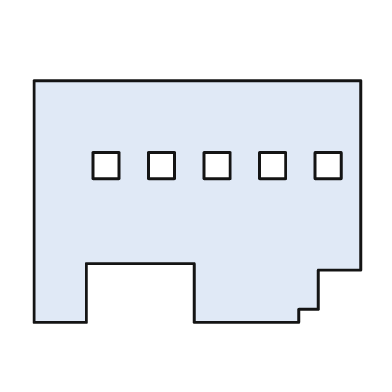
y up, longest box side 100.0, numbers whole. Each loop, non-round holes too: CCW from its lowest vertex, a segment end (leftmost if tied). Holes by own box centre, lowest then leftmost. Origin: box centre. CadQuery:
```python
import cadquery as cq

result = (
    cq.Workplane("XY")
    .moveTo(-50.0, -37.0)
    .lineTo(-34.0, -37.0)
    .lineTo(-34.0, -19.0)
    .lineTo(-1.0, -19.0)
    .lineTo(-1.0, -37.0)
    .lineTo(31.0, -37.0)
    .lineTo(31.0, -33.0)
    .lineTo(37.0, -33.0)
    .lineTo(37.0, -21.0)
    .lineTo(50.0, -21.0)
    .lineTo(50.0, 37.0)
    .lineTo(-50.0, 37.0)
    .close()
    .moveTo(-32.0, 7.0)
    .lineTo(-24.0, 7.0)
    .lineTo(-24.0, 15.0)
    .lineTo(-32.0, 15.0)
    .close()
    .moveTo(-15.0, 7.0)
    .lineTo(-7.0, 7.0)
    .lineTo(-7.0, 15.0)
    .lineTo(-15.0, 15.0)
    .close()
    .moveTo(2.0, 7.0)
    .lineTo(10.0, 7.0)
    .lineTo(10.0, 15.0)
    .lineTo(2.0, 15.0)
    .close()
    .moveTo(19.0, 7.0)
    .lineTo(27.0, 7.0)
    .lineTo(27.0, 15.0)
    .lineTo(19.0, 15.0)
    .close()
    .moveTo(36.0, 7.0)
    .lineTo(44.0, 7.0)
    .lineTo(44.0, 15.0)
    .lineTo(36.0, 15.0)
    .close()
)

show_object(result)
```